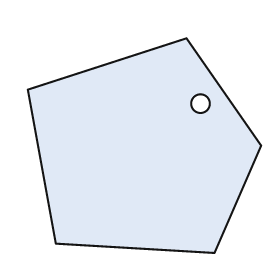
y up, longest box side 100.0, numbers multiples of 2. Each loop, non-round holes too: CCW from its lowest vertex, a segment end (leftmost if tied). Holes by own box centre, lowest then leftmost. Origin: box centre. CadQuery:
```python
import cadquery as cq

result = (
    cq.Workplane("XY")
    .moveTo(30.0, -46.0)
    .lineTo(50.0, 0.0)
    .lineTo(18.0, 46.0)
    .lineTo(-50.0, 24.0)
    .lineTo(-38.0, -42.0)
    .close()
    .moveTo(24.0, 18.0)
    .circle(4.0)
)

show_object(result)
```